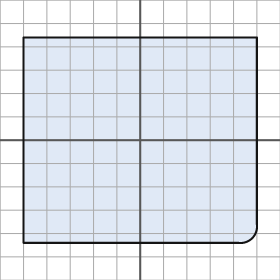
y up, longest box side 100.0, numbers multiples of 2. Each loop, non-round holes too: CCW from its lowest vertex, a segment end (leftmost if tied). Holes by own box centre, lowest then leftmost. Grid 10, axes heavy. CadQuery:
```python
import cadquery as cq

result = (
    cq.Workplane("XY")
    .moveTo(-50.0, -44.0)
    .lineTo(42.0, -44.0)
    .threePointArc((48.0, -42.0), (50.0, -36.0))
    .lineTo(50.0, 44.0)
    .lineTo(-50.0, 44.0)
    .close()
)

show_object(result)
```